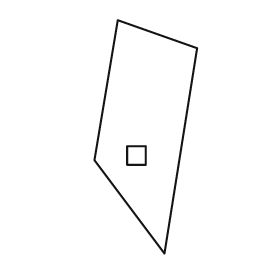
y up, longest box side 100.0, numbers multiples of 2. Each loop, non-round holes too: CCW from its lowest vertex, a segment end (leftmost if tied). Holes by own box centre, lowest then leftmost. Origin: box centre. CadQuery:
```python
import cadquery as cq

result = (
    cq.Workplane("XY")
    .moveTo(8.0, -50.0)
    .lineTo(22.0, 38.0)
    .lineTo(-12.0, 50.0)
    .lineTo(-22.0, -10.0)
    .close()
    .moveTo(-8.0, -12.0)
    .lineTo(0.0, -12.0)
    .lineTo(0.0, -4.0)
    .lineTo(-8.0, -4.0)
    .close()
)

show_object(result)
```